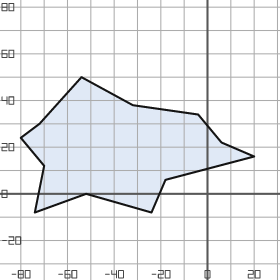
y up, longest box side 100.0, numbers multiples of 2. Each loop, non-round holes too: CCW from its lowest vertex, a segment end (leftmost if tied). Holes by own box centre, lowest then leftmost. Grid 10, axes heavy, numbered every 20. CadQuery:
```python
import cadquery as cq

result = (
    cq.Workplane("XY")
    .moveTo(-74.0, -8.0)
    .lineTo(-52.0, 0.0)
    .lineTo(-24.0, -8.0)
    .lineTo(-18.0, 6.0)
    .lineTo(20.0, 16.0)
    .lineTo(6.0, 22.0)
    .lineTo(-4.0, 34.0)
    .lineTo(-32.0, 38.0)
    .lineTo(-54.0, 50.0)
    .lineTo(-72.0, 30.0)
    .lineTo(-80.0, 24.0)
    .lineTo(-70.0, 12.0)
    .close()
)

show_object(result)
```